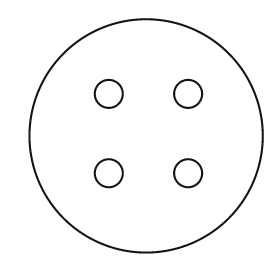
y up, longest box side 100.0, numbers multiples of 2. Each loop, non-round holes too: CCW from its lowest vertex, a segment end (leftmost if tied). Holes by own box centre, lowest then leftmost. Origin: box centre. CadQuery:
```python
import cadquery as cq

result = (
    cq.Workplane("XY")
    .moveTo(0.0, 0.0)
    .circle(50.0)
    .moveTo(-16.0, -16.0)
    .circle(6.0)
    .moveTo(18.0, -16.0)
    .circle(6.0)
    .moveTo(-16.0, 18.0)
    .circle(6.0)
    .moveTo(18.0, 18.0)
    .circle(6.0)
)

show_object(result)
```